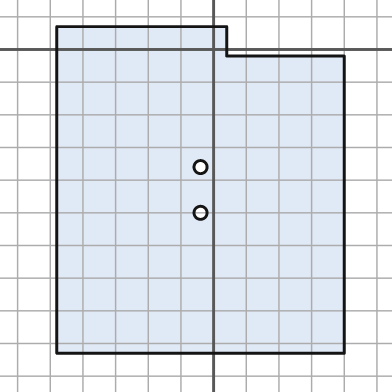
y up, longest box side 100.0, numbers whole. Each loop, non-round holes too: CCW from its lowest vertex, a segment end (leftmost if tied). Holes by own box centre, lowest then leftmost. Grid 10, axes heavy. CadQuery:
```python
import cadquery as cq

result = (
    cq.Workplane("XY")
    .moveTo(-48.0, -93.0)
    .lineTo(40.0, -93.0)
    .lineTo(40.0, -2.0)
    .lineTo(4.0, -2.0)
    .lineTo(4.0, 7.0)
    .lineTo(-48.0, 7.0)
    .close()
    .moveTo(-4.0, -50.0)
    .circle(2.0)
    .moveTo(-4.0, -36.0)
    .circle(2.0)
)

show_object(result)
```